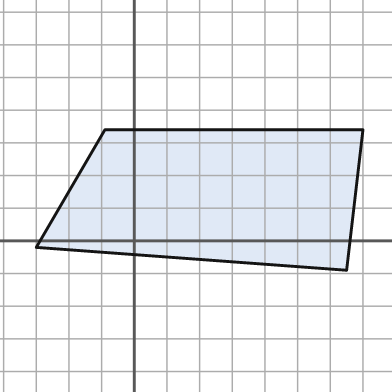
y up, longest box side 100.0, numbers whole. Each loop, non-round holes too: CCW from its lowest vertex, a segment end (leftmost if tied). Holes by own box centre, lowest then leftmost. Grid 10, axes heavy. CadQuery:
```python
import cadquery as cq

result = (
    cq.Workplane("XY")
    .moveTo(65.0, -9.0)
    .lineTo(70.0, 34.0)
    .lineTo(-9.0, 34.0)
    .lineTo(-30.0, -2.0)
    .close()
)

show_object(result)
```